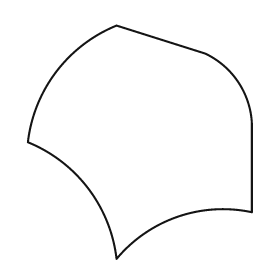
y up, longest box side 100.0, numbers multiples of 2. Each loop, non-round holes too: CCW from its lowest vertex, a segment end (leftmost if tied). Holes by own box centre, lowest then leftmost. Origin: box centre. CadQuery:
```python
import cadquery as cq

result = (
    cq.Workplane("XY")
    .moveTo(-10.0, -50.0)
    .threePointArc((16.0, -32.0), (48.0, -30.0))
    .lineTo(48.0, 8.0)
    .threePointArc((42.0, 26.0), (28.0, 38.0))
    .lineTo(-10.0, 50.0)
    .threePointArc((-36.0, 30.0), (-48.0, 0.0))
    .threePointArc((-22.0, -20.0), (-10.0, -50.0))
    .close()
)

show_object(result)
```